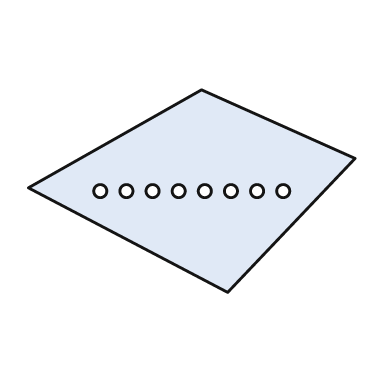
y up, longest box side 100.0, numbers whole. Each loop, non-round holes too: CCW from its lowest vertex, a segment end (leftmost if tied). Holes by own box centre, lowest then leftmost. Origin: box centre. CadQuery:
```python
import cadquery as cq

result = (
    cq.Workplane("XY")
    .moveTo(11.0, -31.0)
    .lineTo(50.0, 10.0)
    .lineTo(3.0, 31.0)
    .lineTo(-50.0, 1.0)
    .close()
    .moveTo(-28.0, 0.0)
    .circle(2.0)
    .moveTo(-20.0, 0.0)
    .circle(2.0)
    .moveTo(-12.0, 0.0)
    .circle(2.0)
    .moveTo(-4.0, 0.0)
    .circle(2.0)
    .moveTo(4.0, 0.0)
    .circle(2.0)
    .moveTo(12.0, 0.0)
    .circle(2.0)
    .moveTo(20.0, 0.0)
    .circle(2.0)
    .moveTo(28.0, 0.0)
    .circle(2.0)
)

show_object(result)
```